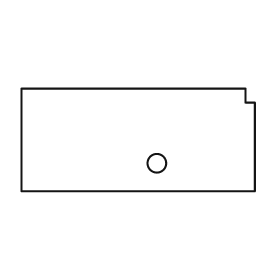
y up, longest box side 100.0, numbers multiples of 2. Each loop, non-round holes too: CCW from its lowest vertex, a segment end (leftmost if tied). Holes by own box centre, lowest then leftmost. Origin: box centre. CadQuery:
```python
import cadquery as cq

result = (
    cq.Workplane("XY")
    .moveTo(-50.0, -22.0)
    .lineTo(50.0, -22.0)
    .lineTo(50.0, 16.0)
    .lineTo(46.0, 16.0)
    .lineTo(46.0, 22.0)
    .lineTo(-50.0, 22.0)
    .close()
    .moveTo(8.0, -10.0)
    .circle(4.0)
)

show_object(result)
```